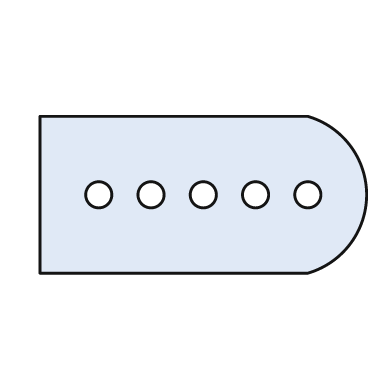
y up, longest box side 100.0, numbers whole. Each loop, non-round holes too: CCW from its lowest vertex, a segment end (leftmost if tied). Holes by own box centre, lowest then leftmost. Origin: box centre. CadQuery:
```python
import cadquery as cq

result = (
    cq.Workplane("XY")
    .moveTo(-50.0, -24.0)
    .lineTo(32.0, -24.0)
    .threePointArc((50.0, 0.0), (32.0, 24.0))
    .lineTo(-50.0, 24.0)
    .close()
    .moveTo(-32.0, 0.0)
    .circle(4.0)
    .moveTo(-16.0, 0.0)
    .circle(4.0)
    .moveTo(0.0, 0.0)
    .circle(4.0)
    .moveTo(16.0, 0.0)
    .circle(4.0)
    .moveTo(32.0, 0.0)
    .circle(4.0)
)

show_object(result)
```